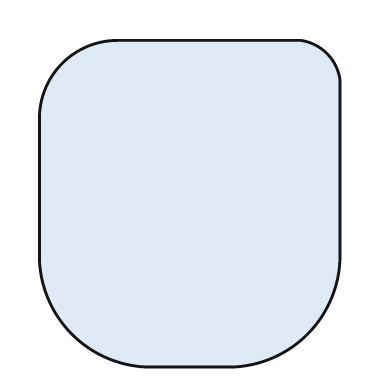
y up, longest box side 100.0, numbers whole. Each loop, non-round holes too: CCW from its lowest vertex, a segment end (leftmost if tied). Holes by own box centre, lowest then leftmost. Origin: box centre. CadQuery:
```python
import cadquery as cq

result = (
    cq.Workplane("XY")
    .moveTo(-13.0, -50.0)
    .lineTo(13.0, -50.0)
    .threePointArc((36.0, -40.0), (46.0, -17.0))
    .lineTo(46.0, 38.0)
    .threePointArc((42.0, 46.0), (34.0, 50.0))
    .lineTo(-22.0, 50.0)
    .threePointArc((-39.0, 43.0), (-46.0, 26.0))
    .lineTo(-46.0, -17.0)
    .threePointArc((-36.0, -40.0), (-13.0, -50.0))
    .close()
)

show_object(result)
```